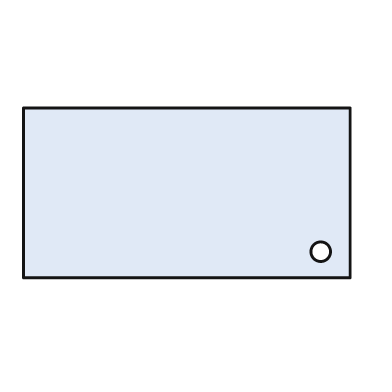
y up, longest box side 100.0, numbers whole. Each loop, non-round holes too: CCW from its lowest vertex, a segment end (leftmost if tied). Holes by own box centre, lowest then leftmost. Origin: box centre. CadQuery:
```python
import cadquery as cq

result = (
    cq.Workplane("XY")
    .moveTo(-50.0, -26.0)
    .lineTo(50.0, -26.0)
    .lineTo(50.0, 26.0)
    .lineTo(-50.0, 26.0)
    .close()
    .moveTo(41.0, -18.0)
    .circle(3.0)
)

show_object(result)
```